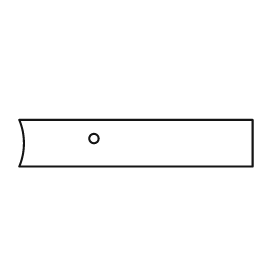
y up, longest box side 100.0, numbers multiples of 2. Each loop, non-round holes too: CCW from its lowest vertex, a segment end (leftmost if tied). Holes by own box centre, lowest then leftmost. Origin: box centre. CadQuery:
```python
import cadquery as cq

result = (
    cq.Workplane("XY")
    .moveTo(-50.0, -10.0)
    .lineTo(50.0, -10.0)
    .lineTo(50.0, 10.0)
    .lineTo(-50.0, 10.0)
    .threePointArc((-48.0, 0.0), (-50.0, -10.0))
    .close()
    .moveTo(-18.0, 2.0)
    .circle(2.0)
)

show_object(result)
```